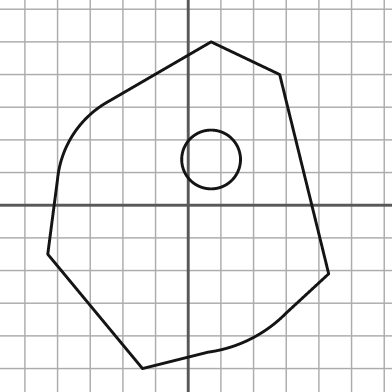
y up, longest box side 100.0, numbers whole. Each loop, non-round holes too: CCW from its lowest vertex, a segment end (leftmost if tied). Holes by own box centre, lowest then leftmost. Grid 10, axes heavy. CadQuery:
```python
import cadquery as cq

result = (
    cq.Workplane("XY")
    .moveTo(-14.0, -50.0)
    .lineTo(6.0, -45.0)
    .threePointArc((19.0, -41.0), (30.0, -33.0))
    .lineTo(43.0, -21.0)
    .lineTo(28.0, 40.0)
    .lineTo(7.0, 50.0)
    .lineTo(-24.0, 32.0)
    .threePointArc((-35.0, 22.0), (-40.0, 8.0))
    .lineTo(-43.0, -15.0)
    .close()
    .moveTo(7.0, 14.0)
    .circle(9.0)
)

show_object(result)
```